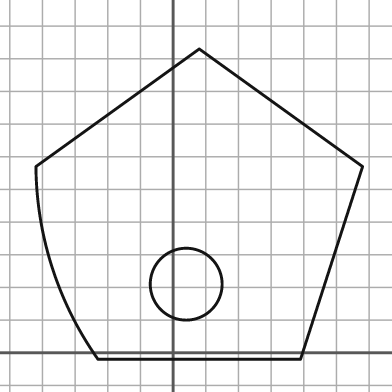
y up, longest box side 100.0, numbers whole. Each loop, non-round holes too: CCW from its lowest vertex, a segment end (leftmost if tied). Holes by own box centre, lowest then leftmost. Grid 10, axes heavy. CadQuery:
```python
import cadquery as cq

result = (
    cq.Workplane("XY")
    .moveTo(-23.0, -2.0)
    .lineTo(39.0, -2.0)
    .lineTo(58.0, 57.0)
    .lineTo(8.0, 93.0)
    .lineTo(-42.0, 57.0)
    .threePointArc((-37.0, 26.0), (-23.0, -2.0))
    .close()
    .moveTo(4.0, 21.0)
    .circle(11.0)
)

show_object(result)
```